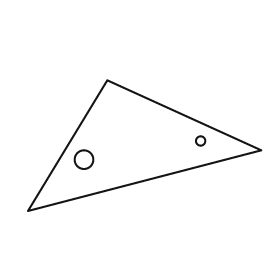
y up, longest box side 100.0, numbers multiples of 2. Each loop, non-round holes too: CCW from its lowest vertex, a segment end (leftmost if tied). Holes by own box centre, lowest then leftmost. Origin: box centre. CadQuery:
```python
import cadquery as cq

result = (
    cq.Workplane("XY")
    .moveTo(-50.0, -28.0)
    .lineTo(50.0, -2.0)
    .lineTo(-16.0, 28.0)
    .close()
    .moveTo(-26.0, -6.0)
    .circle(4.0)
    .moveTo(24.0, 2.0)
    .circle(2.0)
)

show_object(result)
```